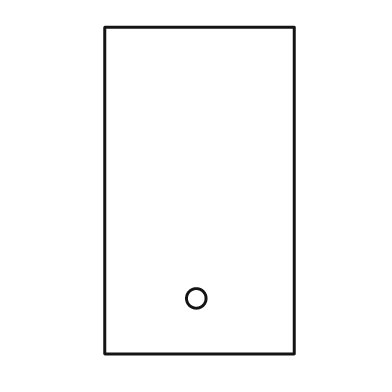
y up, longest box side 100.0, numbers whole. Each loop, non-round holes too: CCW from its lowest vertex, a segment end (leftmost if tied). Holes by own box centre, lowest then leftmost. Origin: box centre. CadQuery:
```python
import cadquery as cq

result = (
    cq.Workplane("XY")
    .moveTo(-29.0, -50.0)
    .lineTo(29.0, -50.0)
    .lineTo(29.0, 50.0)
    .lineTo(-29.0, 50.0)
    .close()
    .moveTo(-1.0, -33.0)
    .circle(3.0)
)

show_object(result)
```